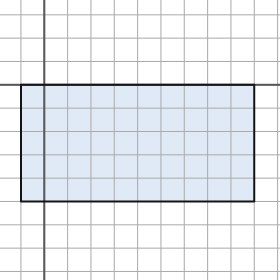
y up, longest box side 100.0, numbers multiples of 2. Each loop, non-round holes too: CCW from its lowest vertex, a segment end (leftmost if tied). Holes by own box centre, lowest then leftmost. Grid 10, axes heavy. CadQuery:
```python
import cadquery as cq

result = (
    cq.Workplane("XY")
    .moveTo(-10.0, -50.0)
    .lineTo(90.0, -50.0)
    .lineTo(90.0, 0.0)
    .lineTo(-10.0, 0.0)
    .close()
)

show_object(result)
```